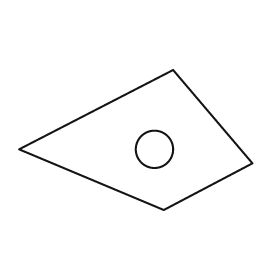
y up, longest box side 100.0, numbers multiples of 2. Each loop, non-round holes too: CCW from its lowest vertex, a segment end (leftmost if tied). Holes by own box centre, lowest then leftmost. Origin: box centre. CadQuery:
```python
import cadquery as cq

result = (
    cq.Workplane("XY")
    .moveTo(12.0, -30.0)
    .lineTo(50.0, -10.0)
    .lineTo(16.0, 30.0)
    .lineTo(-50.0, -4.0)
    .close()
    .moveTo(8.0, -4.0)
    .circle(8.0)
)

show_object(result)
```